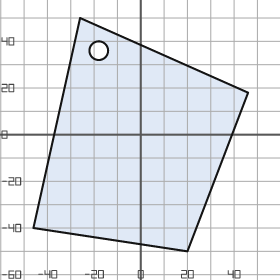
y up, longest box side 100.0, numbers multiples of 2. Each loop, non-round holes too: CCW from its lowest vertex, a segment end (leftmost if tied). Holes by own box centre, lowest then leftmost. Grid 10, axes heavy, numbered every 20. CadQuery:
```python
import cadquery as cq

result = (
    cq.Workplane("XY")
    .moveTo(20.0, -50.0)
    .lineTo(46.0, 18.0)
    .lineTo(-26.0, 50.0)
    .lineTo(-46.0, -40.0)
    .close()
    .moveTo(-18.0, 36.0)
    .circle(4.0)
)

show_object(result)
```